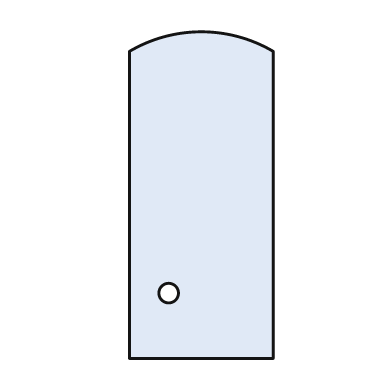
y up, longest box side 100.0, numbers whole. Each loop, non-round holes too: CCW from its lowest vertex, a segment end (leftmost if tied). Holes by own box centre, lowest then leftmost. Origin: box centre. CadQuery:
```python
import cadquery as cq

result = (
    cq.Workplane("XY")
    .moveTo(-22.0, -50.0)
    .lineTo(22.0, -50.0)
    .lineTo(22.0, 44.0)
    .threePointArc((0.0, 50.0), (-22.0, 44.0))
    .close()
    .moveTo(-10.0, -30.0)
    .circle(3.0)
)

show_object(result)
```